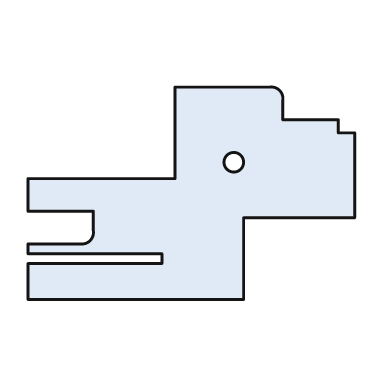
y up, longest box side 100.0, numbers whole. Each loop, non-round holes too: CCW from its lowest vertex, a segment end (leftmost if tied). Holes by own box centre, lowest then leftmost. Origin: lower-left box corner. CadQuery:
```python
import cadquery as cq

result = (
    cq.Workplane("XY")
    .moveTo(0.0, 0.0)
    .lineTo(66.0, 0.0)
    .lineTo(66.0, 25.0)
    .lineTo(100.0, 25.0)
    .lineTo(100.0, 51.0)
    .lineTo(95.0, 51.0)
    .lineTo(95.0, 55.0)
    .lineTo(78.0, 55.0)
    .lineTo(78.0, 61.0)
    .threePointArc((77.0, 64.0), (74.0, 65.0))
    .lineTo(45.0, 65.0)
    .lineTo(45.0, 37.0)
    .lineTo(0.0, 37.0)
    .lineTo(0.0, 27.0)
    .lineTo(20.0, 27.0)
    .lineTo(20.0, 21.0)
    .threePointArc((19.0, 18.0), (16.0, 17.0))
    .lineTo(0.0, 17.0)
    .lineTo(0.0, 14.0)
    .lineTo(41.0, 14.0)
    .lineTo(41.0, 11.0)
    .lineTo(0.0, 11.0)
    .close()
    .moveTo(63.0, 42.0)
    .circle(3.0)
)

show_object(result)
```